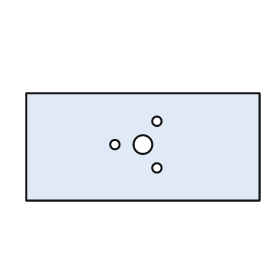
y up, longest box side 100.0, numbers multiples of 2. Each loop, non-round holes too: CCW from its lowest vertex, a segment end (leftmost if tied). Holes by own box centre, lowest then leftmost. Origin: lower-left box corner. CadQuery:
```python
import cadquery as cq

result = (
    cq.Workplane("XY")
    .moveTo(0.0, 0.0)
    .lineTo(100.0, 0.0)
    .lineTo(100.0, 46.0)
    .lineTo(0.0, 46.0)
    .close()
    .moveTo(56.0, 14.0)
    .circle(2.0)
    .moveTo(38.0, 24.0)
    .circle(2.0)
    .moveTo(50.0, 24.0)
    .circle(4.0)
    .moveTo(56.0, 34.0)
    .circle(2.0)
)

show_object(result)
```